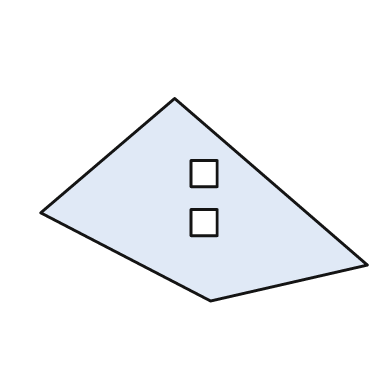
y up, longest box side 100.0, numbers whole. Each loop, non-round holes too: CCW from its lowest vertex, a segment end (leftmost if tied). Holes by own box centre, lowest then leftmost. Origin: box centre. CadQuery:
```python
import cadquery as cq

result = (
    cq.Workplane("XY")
    .moveTo(2.0, -31.0)
    .lineTo(50.0, -20.0)
    .lineTo(-9.0, 31.0)
    .lineTo(-50.0, -4.0)
    .close()
    .moveTo(-4.0, -11.0)
    .lineTo(4.0, -11.0)
    .lineTo(4.0, -3.0)
    .lineTo(-4.0, -3.0)
    .close()
    .moveTo(-4.0, 4.0)
    .lineTo(4.0, 4.0)
    .lineTo(4.0, 12.0)
    .lineTo(-4.0, 12.0)
    .close()
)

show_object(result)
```